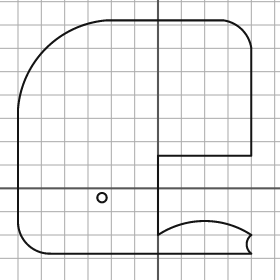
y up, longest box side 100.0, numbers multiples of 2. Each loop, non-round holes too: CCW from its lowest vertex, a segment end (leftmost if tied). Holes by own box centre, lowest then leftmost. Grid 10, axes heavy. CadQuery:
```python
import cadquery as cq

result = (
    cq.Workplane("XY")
    .moveTo(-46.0, -28.0)
    .lineTo(40.0, -28.0)
    .threePointArc((38.0, -24.0), (40.0, -20.0))
    .threePointArc((20.0, -14.0), (0.0, -20.0))
    .lineTo(0.0, 14.0)
    .lineTo(40.0, 14.0)
    .lineTo(40.0, 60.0)
    .threePointArc((36.0, 68.0), (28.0, 72.0))
    .lineTo(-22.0, 72.0)
    .threePointArc((-48.0, 60.0), (-60.0, 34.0))
    .lineTo(-60.0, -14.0)
    .threePointArc((-56.0, -24.0), (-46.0, -28.0))
    .close()
    .moveTo(-24.0, -4.0)
    .circle(2.0)
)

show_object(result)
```